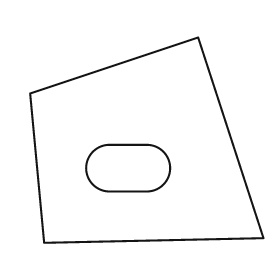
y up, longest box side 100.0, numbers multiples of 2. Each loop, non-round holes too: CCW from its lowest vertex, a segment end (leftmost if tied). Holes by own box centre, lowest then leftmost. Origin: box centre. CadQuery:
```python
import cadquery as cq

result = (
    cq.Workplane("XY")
    .moveTo(-44.0, -44.0)
    .lineTo(50.0, -42.0)
    .lineTo(22.0, 44.0)
    .lineTo(-50.0, 20.0)
    .close()
    .moveTo(-16.0, -22.0)
    .lineTo(0.0, -22.0)
    .threePointArc((10.0, -12.0), (0.0, -2.0))
    .lineTo(-16.0, -2.0)
    .threePointArc((-26.0, -12.0), (-16.0, -22.0))
    .close()
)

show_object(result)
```